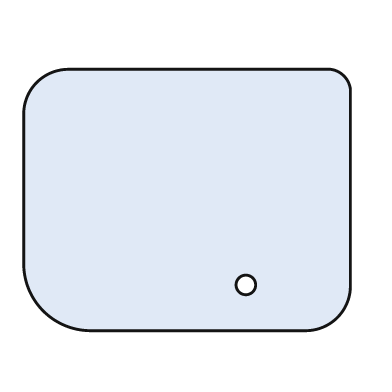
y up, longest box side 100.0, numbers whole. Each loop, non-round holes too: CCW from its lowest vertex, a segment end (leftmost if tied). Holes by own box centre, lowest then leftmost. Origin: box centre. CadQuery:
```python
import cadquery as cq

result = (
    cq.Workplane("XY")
    .moveTo(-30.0, -40.0)
    .lineTo(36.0, -40.0)
    .threePointArc((46.0, -36.0), (50.0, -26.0))
    .lineTo(50.0, 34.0)
    .threePointArc((48.0, 38.0), (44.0, 40.0))
    .lineTo(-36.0, 40.0)
    .threePointArc((-46.0, 36.0), (-50.0, 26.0))
    .lineTo(-50.0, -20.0)
    .threePointArc((-44.0, -34.0), (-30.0, -40.0))
    .close()
    .moveTo(18.0, -26.0)
    .circle(3.0)
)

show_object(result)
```